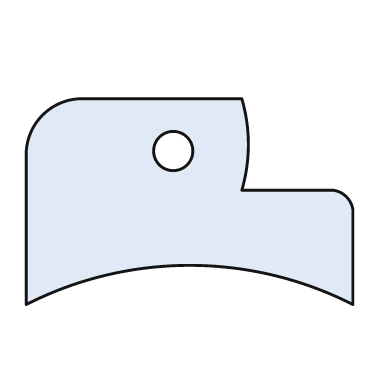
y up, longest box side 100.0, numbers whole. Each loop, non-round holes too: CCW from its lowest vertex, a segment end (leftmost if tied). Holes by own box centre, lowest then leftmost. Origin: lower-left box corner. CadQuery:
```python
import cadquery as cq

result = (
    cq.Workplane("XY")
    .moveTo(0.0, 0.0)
    .threePointArc((50.0, 12.0), (100.0, 0.0))
    .lineTo(100.0, 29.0)
    .threePointArc((98.0, 33.0), (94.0, 35.0))
    .lineTo(66.0, 35.0)
    .threePointArc((68.0, 49.0), (66.0, 63.0))
    .lineTo(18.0, 63.0)
    .threePointArc((5.0, 58.0), (0.0, 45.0))
    .close()
    .moveTo(45.0, 47.0)
    .circle(6.0)
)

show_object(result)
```